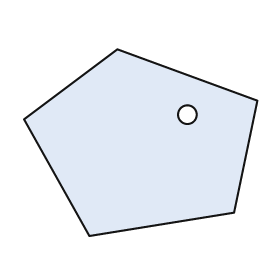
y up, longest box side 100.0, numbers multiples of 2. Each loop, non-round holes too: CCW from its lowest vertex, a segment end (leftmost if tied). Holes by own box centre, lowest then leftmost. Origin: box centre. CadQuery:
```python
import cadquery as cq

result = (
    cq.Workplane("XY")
    .moveTo(-22.0, -40.0)
    .lineTo(40.0, -30.0)
    .lineTo(50.0, 18.0)
    .lineTo(-10.0, 40.0)
    .lineTo(-50.0, 10.0)
    .close()
    .moveTo(20.0, 12.0)
    .circle(4.0)
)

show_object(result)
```